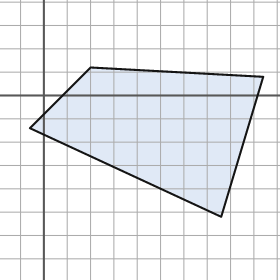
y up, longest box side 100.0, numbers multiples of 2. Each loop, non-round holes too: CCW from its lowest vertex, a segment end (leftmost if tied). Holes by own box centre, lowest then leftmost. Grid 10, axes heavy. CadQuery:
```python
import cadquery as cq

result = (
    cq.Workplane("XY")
    .moveTo(76.0, -52.0)
    .lineTo(94.0, 8.0)
    .lineTo(20.0, 12.0)
    .lineTo(-6.0, -14.0)
    .close()
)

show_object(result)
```